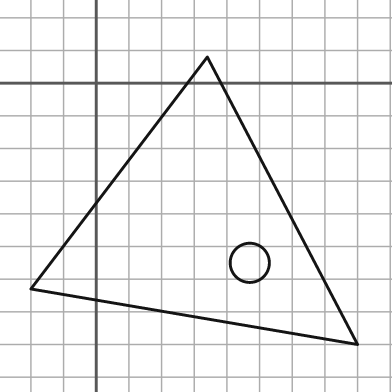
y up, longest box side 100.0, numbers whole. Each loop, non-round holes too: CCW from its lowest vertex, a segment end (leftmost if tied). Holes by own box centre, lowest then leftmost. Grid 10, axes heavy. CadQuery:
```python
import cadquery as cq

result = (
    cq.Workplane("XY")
    .moveTo(80.0, -80.0)
    .lineTo(34.0, 8.0)
    .lineTo(-20.0, -63.0)
    .close()
    .moveTo(47.0, -55.0)
    .circle(6.0)
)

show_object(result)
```